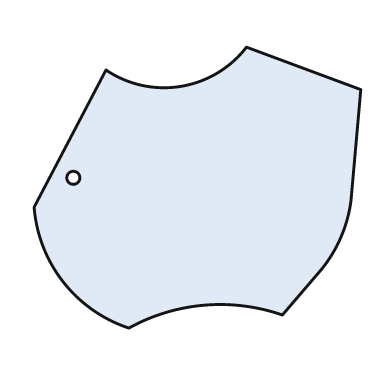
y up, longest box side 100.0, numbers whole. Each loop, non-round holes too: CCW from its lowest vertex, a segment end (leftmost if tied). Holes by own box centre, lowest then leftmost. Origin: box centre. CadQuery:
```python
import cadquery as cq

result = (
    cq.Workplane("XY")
    .moveTo(-21.0, -43.0)
    .threePointArc((2.0, -36.0), (26.0, -39.0))
    .lineTo(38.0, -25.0)
    .threePointArc((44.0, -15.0), (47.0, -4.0))
    .lineTo(50.0, 30.0)
    .lineTo(15.0, 43.0)
    .threePointArc((-5.0, 31.0), (-28.0, 36.0))
    .lineTo(-50.0, -6.0)
    .threePointArc((-41.0, -29.0), (-21.0, -43.0))
    .close()
    .moveTo(-38.0, 3.0)
    .circle(2.0)
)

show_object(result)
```